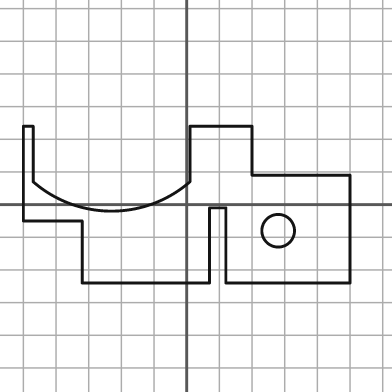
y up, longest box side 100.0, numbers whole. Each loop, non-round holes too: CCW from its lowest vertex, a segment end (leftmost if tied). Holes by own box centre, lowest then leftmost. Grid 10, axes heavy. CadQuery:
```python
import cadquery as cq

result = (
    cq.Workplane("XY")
    .moveTo(-32.0, -24.0)
    .lineTo(7.0, -24.0)
    .lineTo(7.0, -1.0)
    .lineTo(12.0, -1.0)
    .lineTo(12.0, -24.0)
    .lineTo(50.0, -24.0)
    .lineTo(50.0, 9.0)
    .lineTo(20.0, 9.0)
    .lineTo(20.0, 24.0)
    .lineTo(1.0, 24.0)
    .lineTo(1.0, 7.0)
    .threePointArc((-23.0, -2.0), (-47.0, 7.0))
    .lineTo(-47.0, 24.0)
    .lineTo(-50.0, 24.0)
    .lineTo(-50.0, -5.0)
    .lineTo(-32.0, -5.0)
    .close()
    .moveTo(28.0, -8.0)
    .circle(5.0)
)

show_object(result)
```